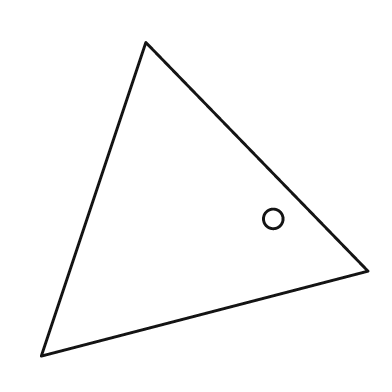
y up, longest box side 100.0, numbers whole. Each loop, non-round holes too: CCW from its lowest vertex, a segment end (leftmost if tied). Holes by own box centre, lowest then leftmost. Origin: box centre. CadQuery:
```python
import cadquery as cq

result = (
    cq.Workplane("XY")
    .moveTo(-50.0, -48.0)
    .lineTo(50.0, -22.0)
    .lineTo(-18.0, 48.0)
    .close()
    .moveTo(21.0, -6.0)
    .circle(3.0)
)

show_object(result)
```